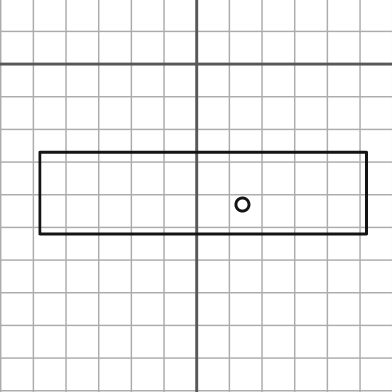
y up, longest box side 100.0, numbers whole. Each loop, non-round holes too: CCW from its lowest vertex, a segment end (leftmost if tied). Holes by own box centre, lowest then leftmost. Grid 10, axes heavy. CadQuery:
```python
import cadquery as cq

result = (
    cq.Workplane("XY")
    .moveTo(-48.0, -52.0)
    .lineTo(52.0, -52.0)
    .lineTo(52.0, -27.0)
    .lineTo(-48.0, -27.0)
    .close()
    .moveTo(14.0, -43.0)
    .circle(2.0)
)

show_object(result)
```